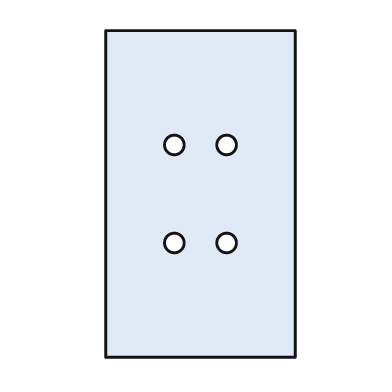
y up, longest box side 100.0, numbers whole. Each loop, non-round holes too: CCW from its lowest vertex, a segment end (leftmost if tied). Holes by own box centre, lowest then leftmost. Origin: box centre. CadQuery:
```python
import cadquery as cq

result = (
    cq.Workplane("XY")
    .moveTo(-29.0, -50.0)
    .lineTo(29.0, -50.0)
    .lineTo(29.0, 50.0)
    .lineTo(-29.0, 50.0)
    .close()
    .moveTo(-8.0, -15.0)
    .circle(3.0)
    .moveTo(8.0, -15.0)
    .circle(3.0)
    .moveTo(-8.0, 15.0)
    .circle(3.0)
    .moveTo(8.0, 15.0)
    .circle(3.0)
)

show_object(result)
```